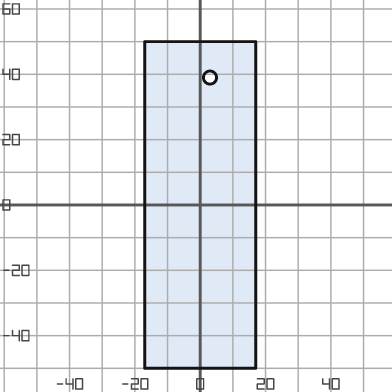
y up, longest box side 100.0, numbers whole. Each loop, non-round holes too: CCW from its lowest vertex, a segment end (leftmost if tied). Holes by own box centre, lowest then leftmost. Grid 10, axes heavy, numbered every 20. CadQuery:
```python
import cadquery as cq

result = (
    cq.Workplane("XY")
    .moveTo(-17.0, -50.0)
    .lineTo(17.0, -50.0)
    .lineTo(17.0, 50.0)
    .lineTo(-17.0, 50.0)
    .close()
    .moveTo(3.0, 39.0)
    .circle(2.0)
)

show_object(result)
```